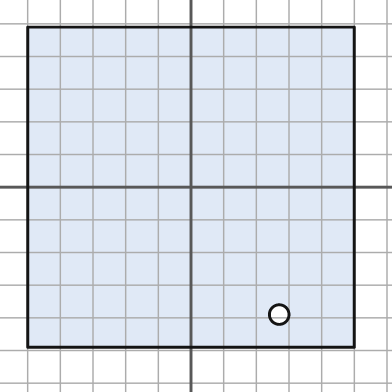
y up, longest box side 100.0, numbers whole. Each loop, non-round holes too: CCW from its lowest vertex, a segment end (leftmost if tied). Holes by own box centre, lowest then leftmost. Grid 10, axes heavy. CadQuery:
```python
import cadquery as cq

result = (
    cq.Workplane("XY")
    .moveTo(-50.0, -49.0)
    .lineTo(50.0, -49.0)
    .lineTo(50.0, 49.0)
    .lineTo(-50.0, 49.0)
    .close()
    .moveTo(27.0, -39.0)
    .circle(3.0)
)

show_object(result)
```